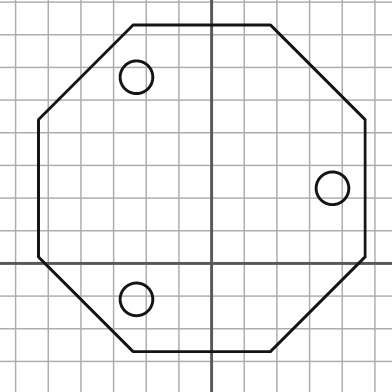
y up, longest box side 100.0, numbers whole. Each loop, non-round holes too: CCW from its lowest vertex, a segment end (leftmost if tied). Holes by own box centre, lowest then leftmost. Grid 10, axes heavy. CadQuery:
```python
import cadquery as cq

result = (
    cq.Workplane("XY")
    .moveTo(-24.0, -27.0)
    .lineTo(18.0, -27.0)
    .lineTo(47.0, 2.0)
    .lineTo(47.0, 44.0)
    .lineTo(18.0, 73.0)
    .lineTo(-24.0, 73.0)
    .lineTo(-53.0, 44.0)
    .lineTo(-53.0, 2.0)
    .close()
    .moveTo(-23.0, -11.0)
    .circle(5.0)
    .moveTo(37.0, 23.0)
    .circle(5.0)
    .moveTo(-23.0, 57.0)
    .circle(5.0)
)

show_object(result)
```